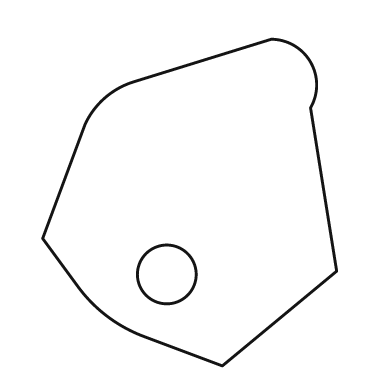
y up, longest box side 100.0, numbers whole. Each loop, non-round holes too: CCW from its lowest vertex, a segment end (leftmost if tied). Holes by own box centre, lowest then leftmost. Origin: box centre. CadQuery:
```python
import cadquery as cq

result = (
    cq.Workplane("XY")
    .moveTo(10.0, -50.0)
    .lineTo(45.0, -21.0)
    .lineTo(37.0, 29.0)
    .threePointArc((37.0, 43.0), (25.0, 50.0))
    .lineTo(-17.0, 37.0)
    .threePointArc((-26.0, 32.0), (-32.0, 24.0))
    .lineTo(-45.0, -11.0)
    .lineTo(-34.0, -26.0)
    .threePointArc((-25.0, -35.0), (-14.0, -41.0))
    .close()
    .moveTo(-7.0, -22.0)
    .circle(9.0)
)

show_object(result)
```